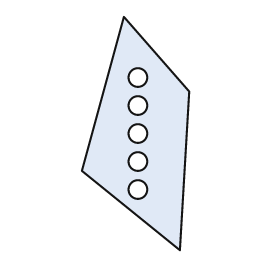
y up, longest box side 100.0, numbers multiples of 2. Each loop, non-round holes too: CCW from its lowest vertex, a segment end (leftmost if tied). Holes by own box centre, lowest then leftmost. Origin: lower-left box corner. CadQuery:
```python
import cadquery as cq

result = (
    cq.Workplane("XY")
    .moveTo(42.0, 0.0)
    .lineTo(46.0, 68.0)
    .lineTo(18.0, 100.0)
    .lineTo(0.0, 34.0)
    .close()
    .moveTo(24.0, 26.0)
    .circle(4.0)
    .moveTo(24.0, 38.0)
    .circle(4.0)
    .moveTo(24.0, 50.0)
    .circle(4.0)
    .moveTo(24.0, 62.0)
    .circle(4.0)
    .moveTo(24.0, 74.0)
    .circle(4.0)
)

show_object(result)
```